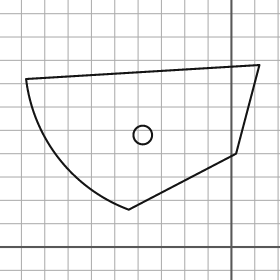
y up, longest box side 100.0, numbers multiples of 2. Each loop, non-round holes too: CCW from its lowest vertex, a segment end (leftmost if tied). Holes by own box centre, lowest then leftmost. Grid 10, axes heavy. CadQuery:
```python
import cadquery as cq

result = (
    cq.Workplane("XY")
    .moveTo(-44.0, 16.0)
    .lineTo(2.0, 40.0)
    .lineTo(12.0, 78.0)
    .lineTo(-88.0, 72.0)
    .threePointArc((-74.0, 38.0), (-44.0, 16.0))
    .close()
    .moveTo(-38.0, 48.0)
    .circle(4.0)
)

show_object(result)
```